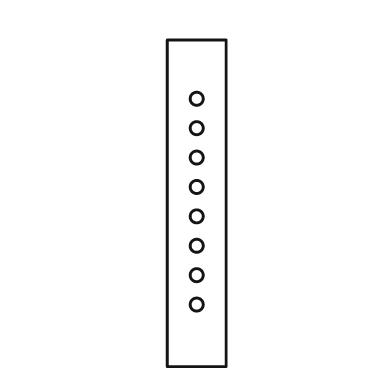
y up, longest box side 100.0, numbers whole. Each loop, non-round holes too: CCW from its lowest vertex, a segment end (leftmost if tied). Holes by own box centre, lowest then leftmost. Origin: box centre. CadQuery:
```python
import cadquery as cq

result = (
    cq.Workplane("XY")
    .moveTo(-9.0, -50.0)
    .lineTo(9.0, -50.0)
    .lineTo(9.0, 50.0)
    .lineTo(-9.0, 50.0)
    .close()
    .moveTo(0.0, -31.0)
    .circle(2.0)
    .moveTo(0.0, -22.0)
    .circle(2.0)
    .moveTo(0.0, -13.0)
    .circle(2.0)
    .moveTo(0.0, -4.0)
    .circle(2.0)
    .moveTo(0.0, 5.0)
    .circle(2.0)
    .moveTo(0.0, 14.0)
    .circle(2.0)
    .moveTo(0.0, 23.0)
    .circle(2.0)
    .moveTo(0.0, 32.0)
    .circle(2.0)
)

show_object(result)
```